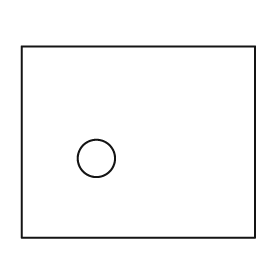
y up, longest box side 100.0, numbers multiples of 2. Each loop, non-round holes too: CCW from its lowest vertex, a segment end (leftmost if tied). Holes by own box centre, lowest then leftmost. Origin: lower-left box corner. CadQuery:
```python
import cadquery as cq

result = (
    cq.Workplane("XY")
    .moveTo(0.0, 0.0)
    .lineTo(100.0, 0.0)
    .lineTo(100.0, 82.0)
    .lineTo(0.0, 82.0)
    .close()
    .moveTo(32.0, 34.0)
    .circle(8.0)
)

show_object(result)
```